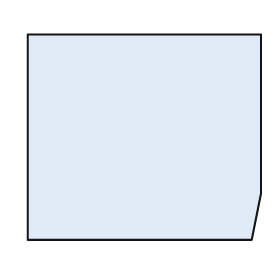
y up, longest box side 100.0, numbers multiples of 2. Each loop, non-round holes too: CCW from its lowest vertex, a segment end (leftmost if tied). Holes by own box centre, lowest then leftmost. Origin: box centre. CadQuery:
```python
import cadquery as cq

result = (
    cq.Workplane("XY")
    .moveTo(-50.0, -44.0)
    .lineTo(46.0, -44.0)
    .lineTo(50.0, -24.0)
    .lineTo(50.0, 44.0)
    .lineTo(-50.0, 44.0)
    .close()
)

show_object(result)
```